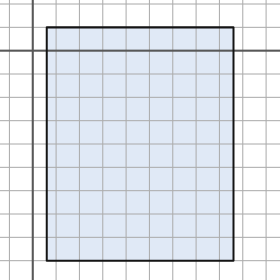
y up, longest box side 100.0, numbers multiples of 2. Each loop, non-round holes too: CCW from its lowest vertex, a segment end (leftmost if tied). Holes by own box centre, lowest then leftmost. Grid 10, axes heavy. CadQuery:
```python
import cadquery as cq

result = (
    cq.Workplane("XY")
    .moveTo(6.0, -90.0)
    .lineTo(86.0, -90.0)
    .lineTo(86.0, 10.0)
    .lineTo(6.0, 10.0)
    .close()
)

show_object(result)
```